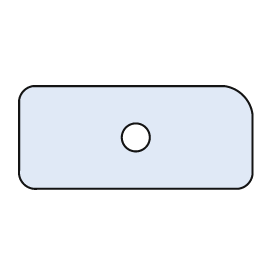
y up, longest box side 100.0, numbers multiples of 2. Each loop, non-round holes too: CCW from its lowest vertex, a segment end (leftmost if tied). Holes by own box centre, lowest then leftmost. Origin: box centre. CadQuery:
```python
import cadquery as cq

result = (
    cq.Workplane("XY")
    .moveTo(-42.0, -22.0)
    .lineTo(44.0, -22.0)
    .threePointArc((48.0, -20.0), (50.0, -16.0))
    .lineTo(50.0, 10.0)
    .threePointArc((46.0, 18.0), (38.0, 22.0))
    .lineTo(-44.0, 22.0)
    .threePointArc((-48.0, 20.0), (-50.0, 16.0))
    .lineTo(-50.0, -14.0)
    .threePointArc((-48.0, -20.0), (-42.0, -22.0))
    .close()
    .moveTo(0.0, 0.0)
    .circle(6.0)
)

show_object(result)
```